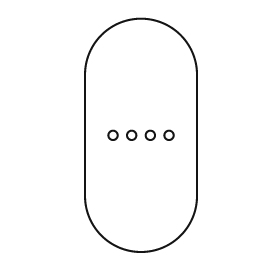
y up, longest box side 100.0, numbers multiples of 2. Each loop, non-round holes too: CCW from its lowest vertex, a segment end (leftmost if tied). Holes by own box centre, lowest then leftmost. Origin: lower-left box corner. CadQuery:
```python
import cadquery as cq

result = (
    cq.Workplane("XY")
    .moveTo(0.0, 24.0)
    .threePointArc((24.0, 0.0), (48.0, 24.0))
    .lineTo(48.0, 76.0)
    .threePointArc((24.0, 100.0), (0.0, 76.0))
    .close()
    .moveTo(12.0, 50.0)
    .circle(2.0)
    .moveTo(20.0, 50.0)
    .circle(2.0)
    .moveTo(28.0, 50.0)
    .circle(2.0)
    .moveTo(36.0, 50.0)
    .circle(2.0)
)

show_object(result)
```